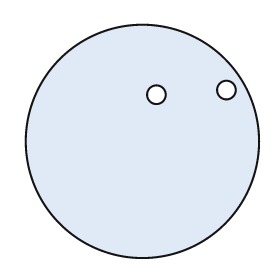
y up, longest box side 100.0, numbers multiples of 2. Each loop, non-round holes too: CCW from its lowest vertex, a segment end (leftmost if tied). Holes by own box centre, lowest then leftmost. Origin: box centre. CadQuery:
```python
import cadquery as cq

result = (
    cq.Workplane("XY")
    .moveTo(0.0, 0.0)
    .circle(50.0)
    .moveTo(6.0, 20.0)
    .circle(4.0)
    .moveTo(36.0, 22.0)
    .circle(4.0)
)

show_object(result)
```